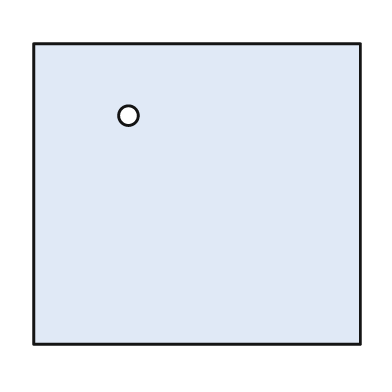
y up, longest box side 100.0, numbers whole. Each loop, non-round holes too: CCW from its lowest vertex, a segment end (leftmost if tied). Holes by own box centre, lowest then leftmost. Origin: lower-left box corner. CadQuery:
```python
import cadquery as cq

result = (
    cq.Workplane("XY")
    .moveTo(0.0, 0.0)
    .lineTo(100.0, 0.0)
    .lineTo(100.0, 92.0)
    .lineTo(0.0, 92.0)
    .close()
    .moveTo(29.0, 70.0)
    .circle(3.0)
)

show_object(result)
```